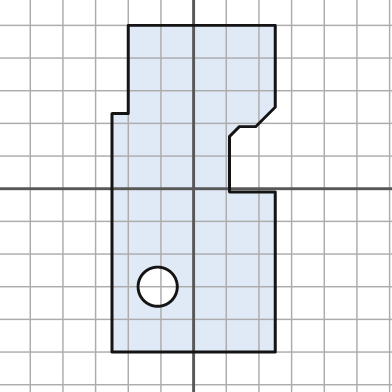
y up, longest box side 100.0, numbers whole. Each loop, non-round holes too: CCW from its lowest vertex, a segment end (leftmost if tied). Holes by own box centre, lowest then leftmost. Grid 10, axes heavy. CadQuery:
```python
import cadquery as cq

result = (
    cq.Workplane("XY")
    .moveTo(-25.0, -50.0)
    .lineTo(25.0, -50.0)
    .lineTo(25.0, -1.0)
    .lineTo(11.0, -1.0)
    .lineTo(11.0, 16.0)
    .lineTo(14.0, 19.0)
    .lineTo(19.0, 19.0)
    .lineTo(25.0, 25.0)
    .lineTo(25.0, 50.0)
    .lineTo(-20.0, 50.0)
    .lineTo(-20.0, 23.0)
    .lineTo(-25.0, 23.0)
    .close()
    .moveTo(-11.0, -30.0)
    .circle(6.0)
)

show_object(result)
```